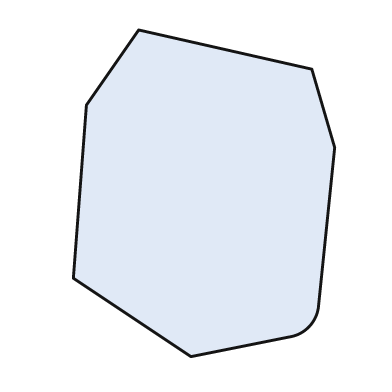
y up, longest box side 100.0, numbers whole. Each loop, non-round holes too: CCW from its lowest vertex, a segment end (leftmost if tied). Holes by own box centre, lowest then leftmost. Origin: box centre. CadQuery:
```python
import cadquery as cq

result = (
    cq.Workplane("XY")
    .moveTo(-4.0, -50.0)
    .lineTo(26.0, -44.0)
    .threePointArc((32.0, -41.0), (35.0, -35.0))
    .lineTo(40.0, 14.0)
    .lineTo(33.0, 38.0)
    .lineTo(-20.0, 50.0)
    .lineTo(-36.0, 27.0)
    .lineTo(-40.0, -26.0)
    .close()
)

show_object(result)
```